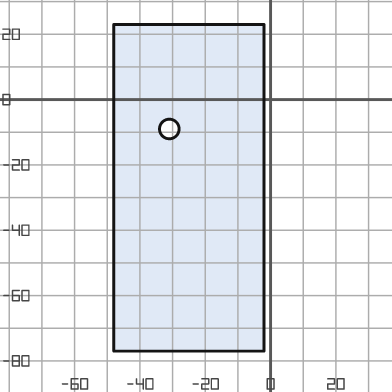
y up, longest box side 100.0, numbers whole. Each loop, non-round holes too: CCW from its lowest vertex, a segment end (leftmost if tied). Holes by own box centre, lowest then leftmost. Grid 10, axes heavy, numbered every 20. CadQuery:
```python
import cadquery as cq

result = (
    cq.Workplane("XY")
    .moveTo(-48.0, -77.0)
    .lineTo(-2.0, -77.0)
    .lineTo(-2.0, 23.0)
    .lineTo(-48.0, 23.0)
    .close()
    .moveTo(-31.0, -9.0)
    .circle(3.0)
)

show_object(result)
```